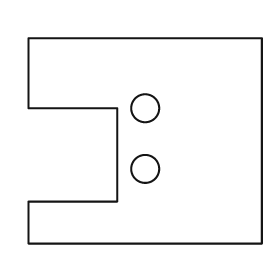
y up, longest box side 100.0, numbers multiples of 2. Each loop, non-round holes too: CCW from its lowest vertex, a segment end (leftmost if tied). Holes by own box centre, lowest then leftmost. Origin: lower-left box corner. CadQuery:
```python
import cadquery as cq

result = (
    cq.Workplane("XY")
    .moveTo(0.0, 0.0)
    .lineTo(100.0, 0.0)
    .lineTo(100.0, 88.0)
    .lineTo(0.0, 88.0)
    .lineTo(0.0, 58.0)
    .lineTo(38.0, 58.0)
    .lineTo(38.0, 18.0)
    .lineTo(0.0, 18.0)
    .close()
    .moveTo(50.0, 32.0)
    .circle(6.0)
    .moveTo(50.0, 58.0)
    .circle(6.0)
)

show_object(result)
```